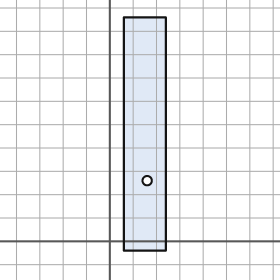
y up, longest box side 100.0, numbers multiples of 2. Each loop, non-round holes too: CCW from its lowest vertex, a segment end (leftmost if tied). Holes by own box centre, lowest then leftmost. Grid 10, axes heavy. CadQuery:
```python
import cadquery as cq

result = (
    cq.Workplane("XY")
    .moveTo(6.0, -4.0)
    .lineTo(24.0, -4.0)
    .lineTo(24.0, 96.0)
    .lineTo(6.0, 96.0)
    .close()
    .moveTo(16.0, 26.0)
    .circle(2.0)
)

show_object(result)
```